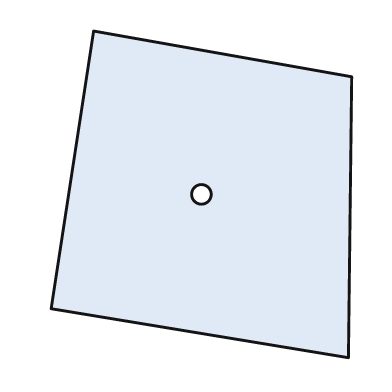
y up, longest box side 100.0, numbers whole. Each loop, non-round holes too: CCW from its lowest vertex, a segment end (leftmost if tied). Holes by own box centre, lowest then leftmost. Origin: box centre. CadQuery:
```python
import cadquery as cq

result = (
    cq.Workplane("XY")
    .moveTo(45.0, -50.0)
    .lineTo(46.0, 36.0)
    .lineTo(-33.0, 50.0)
    .lineTo(-46.0, -35.0)
    .close()
    .moveTo(0.0, 0.0)
    .circle(3.0)
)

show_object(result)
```